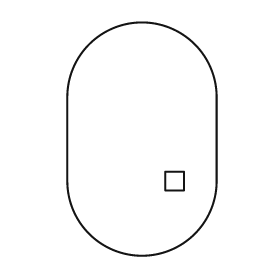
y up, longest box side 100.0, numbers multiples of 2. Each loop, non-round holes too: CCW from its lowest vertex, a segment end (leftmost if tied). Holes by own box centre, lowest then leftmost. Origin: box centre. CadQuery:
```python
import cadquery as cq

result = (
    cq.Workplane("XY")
    .moveTo(-32.0, -18.0)
    .threePointArc((0.0, -50.0), (32.0, -18.0))
    .lineTo(32.0, 18.0)
    .threePointArc((0.0, 50.0), (-32.0, 18.0))
    .close()
    .moveTo(10.0, -22.0)
    .lineTo(18.0, -22.0)
    .lineTo(18.0, -14.0)
    .lineTo(10.0, -14.0)
    .close()
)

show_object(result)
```